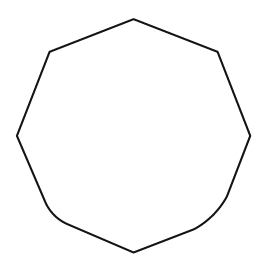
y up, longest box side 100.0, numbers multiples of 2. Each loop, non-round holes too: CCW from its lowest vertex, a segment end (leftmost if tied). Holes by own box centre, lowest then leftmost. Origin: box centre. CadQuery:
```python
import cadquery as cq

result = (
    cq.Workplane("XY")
    .moveTo(0.0, -50.0)
    .lineTo(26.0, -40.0)
    .threePointArc((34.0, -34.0), (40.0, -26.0))
    .lineTo(50.0, 0.0)
    .lineTo(36.0, 36.0)
    .lineTo(0.0, 50.0)
    .lineTo(-36.0, 36.0)
    .lineTo(-50.0, 0.0)
    .lineTo(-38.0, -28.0)
    .threePointArc((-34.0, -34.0), (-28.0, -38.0))
    .close()
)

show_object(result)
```